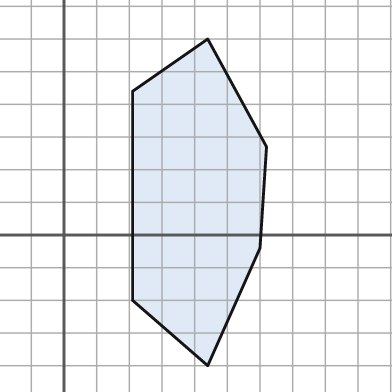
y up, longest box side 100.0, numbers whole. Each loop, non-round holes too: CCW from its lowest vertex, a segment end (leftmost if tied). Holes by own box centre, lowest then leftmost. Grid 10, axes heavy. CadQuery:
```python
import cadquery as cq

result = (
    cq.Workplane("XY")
    .moveTo(44.0, -40.0)
    .lineTo(60.0, -4.0)
    .lineTo(62.0, 27.0)
    .lineTo(44.0, 60.0)
    .lineTo(21.0, 44.0)
    .lineTo(21.0, -20.0)
    .close()
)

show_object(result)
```